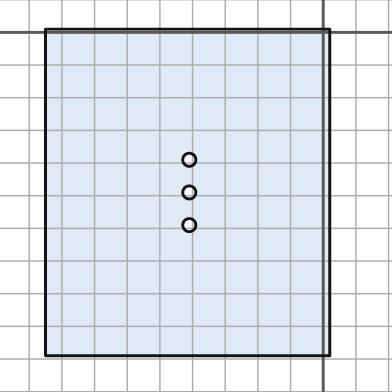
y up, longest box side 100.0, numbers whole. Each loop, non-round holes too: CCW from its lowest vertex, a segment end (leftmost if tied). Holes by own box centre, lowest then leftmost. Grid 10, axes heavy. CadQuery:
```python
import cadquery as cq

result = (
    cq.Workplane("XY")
    .moveTo(-85.0, -99.0)
    .lineTo(2.0, -99.0)
    .lineTo(2.0, 1.0)
    .lineTo(-85.0, 1.0)
    .close()
    .moveTo(-41.0, -59.0)
    .circle(2.0)
    .moveTo(-41.0, -49.0)
    .circle(2.0)
    .moveTo(-41.0, -39.0)
    .circle(2.0)
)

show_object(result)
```